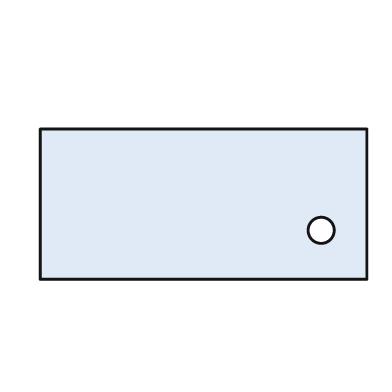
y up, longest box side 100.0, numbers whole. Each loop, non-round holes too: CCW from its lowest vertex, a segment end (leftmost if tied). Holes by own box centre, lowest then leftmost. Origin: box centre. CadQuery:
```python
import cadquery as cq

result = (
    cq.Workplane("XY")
    .moveTo(-50.0, -23.0)
    .lineTo(50.0, -23.0)
    .lineTo(50.0, 23.0)
    .lineTo(-50.0, 23.0)
    .close()
    .moveTo(36.0, -8.0)
    .circle(4.0)
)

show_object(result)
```